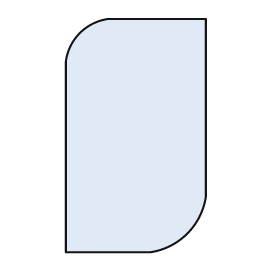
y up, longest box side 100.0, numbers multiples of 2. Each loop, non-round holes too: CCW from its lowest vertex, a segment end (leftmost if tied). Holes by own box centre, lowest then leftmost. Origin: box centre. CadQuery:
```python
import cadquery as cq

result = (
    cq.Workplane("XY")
    .moveTo(-30.0, -50.0)
    .lineTo(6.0, -50.0)
    .threePointArc((22.0, -42.0), (30.0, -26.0))
    .lineTo(30.0, 50.0)
    .lineTo(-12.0, 50.0)
    .threePointArc((-24.0, 44.0), (-30.0, 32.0))
    .close()
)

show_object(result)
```